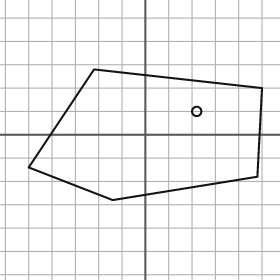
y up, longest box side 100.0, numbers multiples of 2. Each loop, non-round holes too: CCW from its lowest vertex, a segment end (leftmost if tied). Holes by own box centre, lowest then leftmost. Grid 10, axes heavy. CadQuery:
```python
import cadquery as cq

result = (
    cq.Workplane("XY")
    .moveTo(-14.0, -28.0)
    .lineTo(48.0, -18.0)
    .lineTo(50.0, 20.0)
    .lineTo(-22.0, 28.0)
    .lineTo(-50.0, -14.0)
    .close()
    .moveTo(22.0, 10.0)
    .circle(2.0)
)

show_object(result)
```